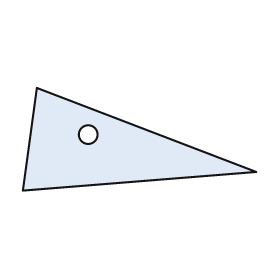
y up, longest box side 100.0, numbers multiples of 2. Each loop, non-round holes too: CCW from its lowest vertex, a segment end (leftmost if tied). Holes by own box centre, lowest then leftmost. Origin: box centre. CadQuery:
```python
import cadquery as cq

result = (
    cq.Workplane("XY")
    .moveTo(-50.0, -22.0)
    .lineTo(50.0, -14.0)
    .lineTo(-44.0, 22.0)
    .close()
    .moveTo(-22.0, 2.0)
    .circle(4.0)
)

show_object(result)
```